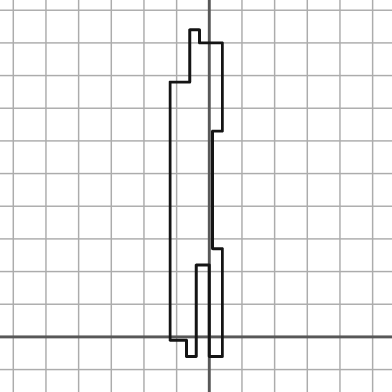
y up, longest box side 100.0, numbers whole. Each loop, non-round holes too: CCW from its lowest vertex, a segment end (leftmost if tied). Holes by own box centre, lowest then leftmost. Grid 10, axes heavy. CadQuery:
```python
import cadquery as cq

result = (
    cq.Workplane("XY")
    .moveTo(-7.0, -6.0)
    .lineTo(-4.0, -6.0)
    .lineTo(-4.0, 22.0)
    .lineTo(0.0, 22.0)
    .lineTo(0.0, -6.0)
    .lineTo(4.0, -6.0)
    .lineTo(4.0, 27.0)
    .lineTo(1.0, 27.0)
    .lineTo(1.0, 63.0)
    .lineTo(4.0, 63.0)
    .lineTo(4.0, 90.0)
    .lineTo(-3.0, 90.0)
    .lineTo(-3.0, 94.0)
    .lineTo(-6.0, 94.0)
    .lineTo(-6.0, 78.0)
    .lineTo(-12.0, 78.0)
    .lineTo(-12.0, -1.0)
    .lineTo(-7.0, -1.0)
    .close()
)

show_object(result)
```